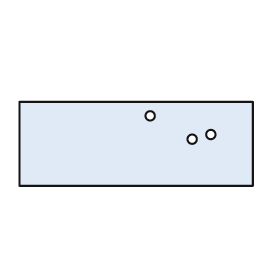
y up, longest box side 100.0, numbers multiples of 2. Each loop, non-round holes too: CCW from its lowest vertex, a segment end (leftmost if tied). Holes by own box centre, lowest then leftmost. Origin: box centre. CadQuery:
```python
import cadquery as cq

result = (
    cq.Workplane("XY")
    .moveTo(-50.0, -18.0)
    .lineTo(50.0, -18.0)
    .lineTo(50.0, 18.0)
    .lineTo(-50.0, 18.0)
    .close()
    .moveTo(24.0, 2.0)
    .circle(2.0)
    .moveTo(32.0, 4.0)
    .circle(2.0)
    .moveTo(6.0, 12.0)
    .circle(2.0)
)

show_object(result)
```